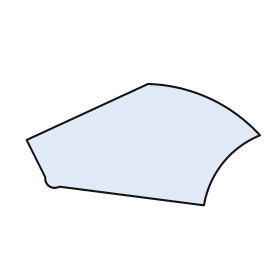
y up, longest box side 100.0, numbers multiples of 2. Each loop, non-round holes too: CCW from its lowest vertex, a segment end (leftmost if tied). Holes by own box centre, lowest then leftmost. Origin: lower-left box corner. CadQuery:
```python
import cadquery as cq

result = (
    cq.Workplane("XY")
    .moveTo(76.0, 0.0)
    .threePointArc((84.0, 18.0), (100.0, 30.0))
    .threePointArc((78.0, 46.0), (52.0, 52.0))
    .lineTo(0.0, 28.0)
    .lineTo(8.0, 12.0)
    .threePointArc((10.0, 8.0), (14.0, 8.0))
    .close()
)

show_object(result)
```